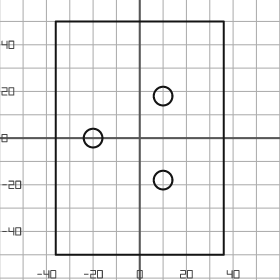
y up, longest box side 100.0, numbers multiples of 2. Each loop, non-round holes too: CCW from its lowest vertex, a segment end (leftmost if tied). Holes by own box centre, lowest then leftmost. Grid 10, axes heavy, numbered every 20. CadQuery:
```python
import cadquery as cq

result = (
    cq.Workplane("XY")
    .moveTo(-36.0, -50.0)
    .lineTo(36.0, -50.0)
    .lineTo(36.0, 50.0)
    .lineTo(-36.0, 50.0)
    .close()
    .moveTo(10.0, -18.0)
    .circle(4.0)
    .moveTo(-20.0, 0.0)
    .circle(4.0)
    .moveTo(10.0, 18.0)
    .circle(4.0)
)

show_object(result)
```